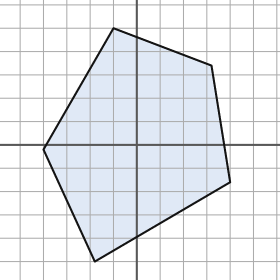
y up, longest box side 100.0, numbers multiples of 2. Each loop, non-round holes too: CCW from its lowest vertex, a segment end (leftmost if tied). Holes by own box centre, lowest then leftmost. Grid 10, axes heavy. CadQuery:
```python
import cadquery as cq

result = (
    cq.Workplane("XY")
    .moveTo(-18.0, -50.0)
    .lineTo(40.0, -16.0)
    .lineTo(32.0, 34.0)
    .lineTo(-10.0, 50.0)
    .lineTo(-40.0, -2.0)
    .close()
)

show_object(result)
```